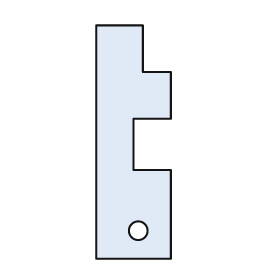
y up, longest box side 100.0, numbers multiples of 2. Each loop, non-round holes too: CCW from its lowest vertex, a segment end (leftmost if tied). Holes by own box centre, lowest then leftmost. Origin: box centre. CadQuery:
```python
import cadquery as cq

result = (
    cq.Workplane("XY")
    .moveTo(-16.0, -50.0)
    .lineTo(16.0, -50.0)
    .lineTo(16.0, -12.0)
    .lineTo(0.0, -12.0)
    .lineTo(0.0, 10.0)
    .lineTo(16.0, 10.0)
    .lineTo(16.0, 30.0)
    .lineTo(4.0, 30.0)
    .lineTo(4.0, 50.0)
    .lineTo(-16.0, 50.0)
    .close()
    .moveTo(2.0, -38.0)
    .circle(4.0)
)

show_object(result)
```